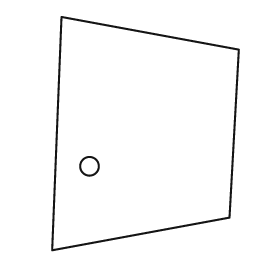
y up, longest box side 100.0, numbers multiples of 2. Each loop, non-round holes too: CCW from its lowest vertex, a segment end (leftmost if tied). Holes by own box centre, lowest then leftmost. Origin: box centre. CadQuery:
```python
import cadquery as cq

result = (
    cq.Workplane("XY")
    .moveTo(-40.0, -50.0)
    .lineTo(36.0, -36.0)
    .lineTo(40.0, 36.0)
    .lineTo(-36.0, 50.0)
    .close()
    .moveTo(-24.0, -14.0)
    .circle(4.0)
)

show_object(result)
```